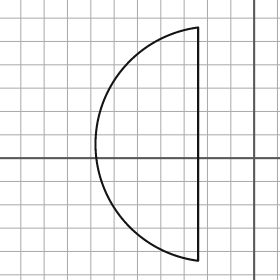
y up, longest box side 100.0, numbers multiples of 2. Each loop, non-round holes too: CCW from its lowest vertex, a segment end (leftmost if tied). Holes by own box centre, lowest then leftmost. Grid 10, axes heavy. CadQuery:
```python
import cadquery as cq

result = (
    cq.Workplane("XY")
    .moveTo(-24.0, -44.0)
    .lineTo(-24.0, 56.0)
    .threePointArc((-68.0, 6.0), (-24.0, -44.0))
    .close()
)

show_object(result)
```